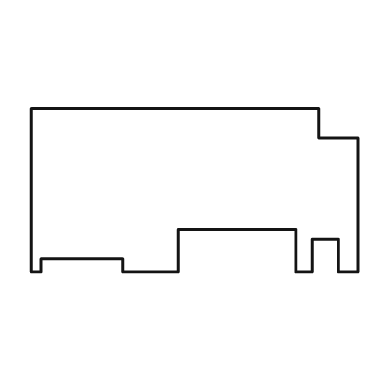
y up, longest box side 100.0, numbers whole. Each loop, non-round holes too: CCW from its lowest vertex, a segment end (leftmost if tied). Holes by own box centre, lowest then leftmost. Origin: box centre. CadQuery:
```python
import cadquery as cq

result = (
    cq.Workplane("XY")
    .moveTo(-50.0, -25.0)
    .lineTo(-47.0, -25.0)
    .lineTo(-47.0, -21.0)
    .lineTo(-22.0, -21.0)
    .lineTo(-22.0, -25.0)
    .lineTo(-5.0, -25.0)
    .lineTo(-5.0, -12.0)
    .lineTo(31.0, -12.0)
    .lineTo(31.0, -25.0)
    .lineTo(36.0, -25.0)
    .lineTo(36.0, -15.0)
    .lineTo(44.0, -15.0)
    .lineTo(44.0, -25.0)
    .lineTo(50.0, -25.0)
    .lineTo(50.0, 16.0)
    .lineTo(38.0, 16.0)
    .lineTo(38.0, 25.0)
    .lineTo(-50.0, 25.0)
    .close()
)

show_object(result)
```